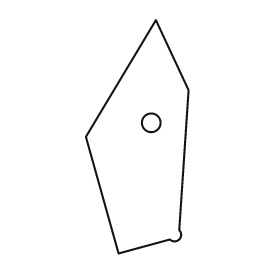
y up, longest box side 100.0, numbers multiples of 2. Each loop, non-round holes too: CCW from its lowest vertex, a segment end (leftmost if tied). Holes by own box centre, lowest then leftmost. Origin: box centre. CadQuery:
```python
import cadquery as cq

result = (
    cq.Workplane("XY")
    .moveTo(-8.0, -50.0)
    .lineTo(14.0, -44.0)
    .threePointArc((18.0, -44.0), (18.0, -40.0))
    .lineTo(22.0, 20.0)
    .lineTo(8.0, 50.0)
    .lineTo(-22.0, 0.0)
    .close()
    .moveTo(6.0, 6.0)
    .circle(4.0)
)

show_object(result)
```